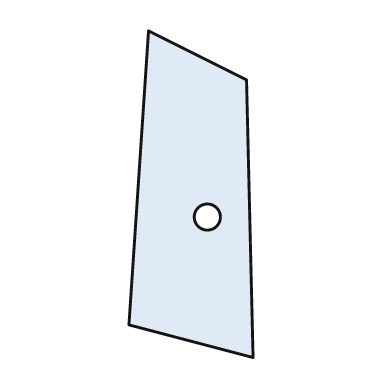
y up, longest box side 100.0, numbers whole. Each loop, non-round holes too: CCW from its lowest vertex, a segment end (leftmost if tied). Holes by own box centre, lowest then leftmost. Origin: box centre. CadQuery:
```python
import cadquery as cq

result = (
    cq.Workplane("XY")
    .moveTo(19.0, -50.0)
    .lineTo(17.0, 35.0)
    .lineTo(-13.0, 50.0)
    .lineTo(-19.0, -40.0)
    .close()
    .moveTo(5.0, -7.0)
    .circle(4.0)
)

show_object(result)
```